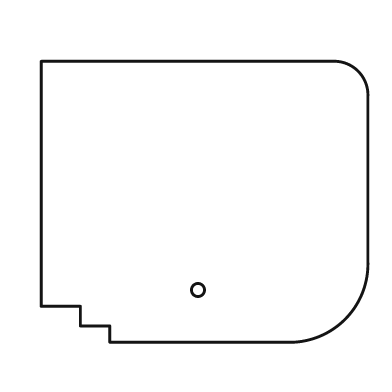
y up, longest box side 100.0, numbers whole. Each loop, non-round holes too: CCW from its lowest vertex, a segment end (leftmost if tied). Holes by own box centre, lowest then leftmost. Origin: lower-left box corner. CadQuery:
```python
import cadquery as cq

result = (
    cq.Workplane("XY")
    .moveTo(21.0, 0.0)
    .lineTo(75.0, 0.0)
    .threePointArc((93.0, 7.0), (100.0, 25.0))
    .lineTo(100.0, 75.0)
    .threePointArc((97.0, 83.0), (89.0, 86.0))
    .lineTo(0.0, 86.0)
    .lineTo(0.0, 11.0)
    .lineTo(12.0, 11.0)
    .lineTo(12.0, 5.0)
    .lineTo(21.0, 5.0)
    .close()
    .moveTo(48.0, 16.0)
    .circle(2.0)
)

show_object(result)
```